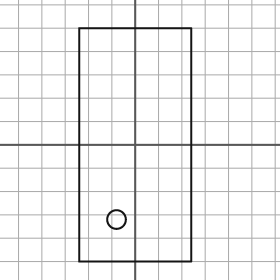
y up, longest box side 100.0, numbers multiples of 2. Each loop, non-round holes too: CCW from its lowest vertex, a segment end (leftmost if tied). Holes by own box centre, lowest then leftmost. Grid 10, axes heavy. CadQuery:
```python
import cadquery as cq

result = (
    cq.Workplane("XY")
    .moveTo(-24.0, -50.0)
    .lineTo(24.0, -50.0)
    .lineTo(24.0, 50.0)
    .lineTo(-24.0, 50.0)
    .close()
    .moveTo(-8.0, -32.0)
    .circle(4.0)
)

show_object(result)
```